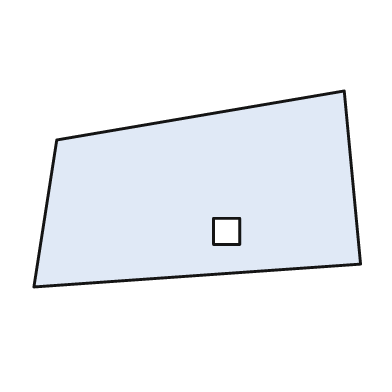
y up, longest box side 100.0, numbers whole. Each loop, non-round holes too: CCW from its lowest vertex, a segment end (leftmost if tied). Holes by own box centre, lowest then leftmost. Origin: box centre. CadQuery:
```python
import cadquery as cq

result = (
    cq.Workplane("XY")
    .moveTo(-50.0, -30.0)
    .lineTo(50.0, -23.0)
    .lineTo(45.0, 30.0)
    .lineTo(-43.0, 15.0)
    .close()
    .moveTo(5.0, -17.0)
    .lineTo(13.0, -17.0)
    .lineTo(13.0, -9.0)
    .lineTo(5.0, -9.0)
    .close()
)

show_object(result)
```